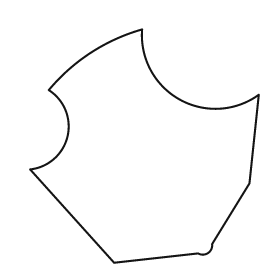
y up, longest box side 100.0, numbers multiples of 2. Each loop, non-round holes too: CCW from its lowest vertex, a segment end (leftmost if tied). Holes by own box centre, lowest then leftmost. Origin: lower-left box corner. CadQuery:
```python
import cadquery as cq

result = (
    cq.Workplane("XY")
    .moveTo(36.0, 0.0)
    .lineTo(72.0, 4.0)
    .threePointArc((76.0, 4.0), (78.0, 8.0))
    .lineTo(94.0, 34.0)
    .lineTo(98.0, 72.0)
    .threePointArc((64.0, 70.0), (48.0, 100.0))
    .threePointArc((26.0, 90.0), (8.0, 74.0))
    .threePointArc((16.0, 54.0), (0.0, 40.0))
    .close()
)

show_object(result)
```